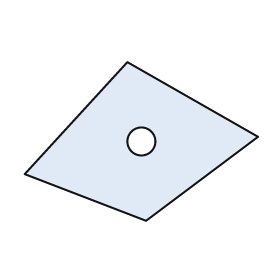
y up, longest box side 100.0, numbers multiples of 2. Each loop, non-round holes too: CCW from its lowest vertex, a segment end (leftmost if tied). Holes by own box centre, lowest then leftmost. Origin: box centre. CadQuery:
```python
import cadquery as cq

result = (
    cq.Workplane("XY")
    .moveTo(2.0, -34.0)
    .lineTo(50.0, 2.0)
    .lineTo(-6.0, 34.0)
    .lineTo(-50.0, -14.0)
    .close()
    .moveTo(0.0, 0.0)
    .circle(6.0)
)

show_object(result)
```